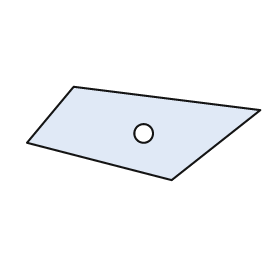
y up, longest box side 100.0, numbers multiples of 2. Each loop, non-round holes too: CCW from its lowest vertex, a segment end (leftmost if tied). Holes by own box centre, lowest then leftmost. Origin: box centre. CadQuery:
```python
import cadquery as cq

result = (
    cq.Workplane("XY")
    .moveTo(12.0, -20.0)
    .lineTo(50.0, 10.0)
    .lineTo(-30.0, 20.0)
    .lineTo(-50.0, -4.0)
    .close()
    .moveTo(0.0, 0.0)
    .circle(4.0)
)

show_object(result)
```